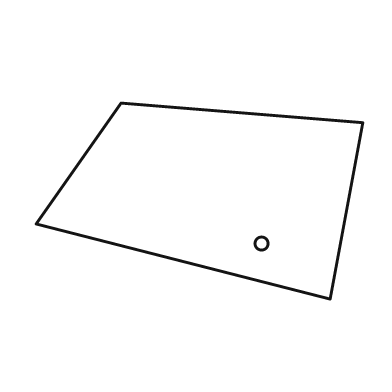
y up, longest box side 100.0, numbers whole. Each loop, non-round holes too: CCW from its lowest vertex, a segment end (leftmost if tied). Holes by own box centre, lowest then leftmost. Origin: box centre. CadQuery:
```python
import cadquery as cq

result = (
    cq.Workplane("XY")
    .moveTo(40.0, -30.0)
    .lineTo(50.0, 24.0)
    .lineTo(-24.0, 30.0)
    .lineTo(-50.0, -7.0)
    .close()
    .moveTo(19.0, -13.0)
    .circle(2.0)
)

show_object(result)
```